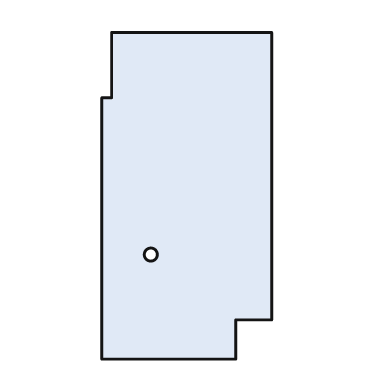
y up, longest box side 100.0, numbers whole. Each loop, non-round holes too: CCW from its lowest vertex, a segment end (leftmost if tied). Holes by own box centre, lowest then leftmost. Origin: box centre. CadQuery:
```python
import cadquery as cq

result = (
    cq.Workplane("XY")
    .moveTo(-26.0, -50.0)
    .lineTo(15.0, -50.0)
    .lineTo(15.0, -38.0)
    .lineTo(26.0, -38.0)
    .lineTo(26.0, 50.0)
    .lineTo(-23.0, 50.0)
    .lineTo(-23.0, 30.0)
    .lineTo(-26.0, 30.0)
    .close()
    .moveTo(-11.0, -18.0)
    .circle(2.0)
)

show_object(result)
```